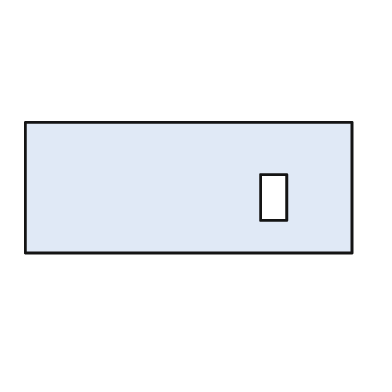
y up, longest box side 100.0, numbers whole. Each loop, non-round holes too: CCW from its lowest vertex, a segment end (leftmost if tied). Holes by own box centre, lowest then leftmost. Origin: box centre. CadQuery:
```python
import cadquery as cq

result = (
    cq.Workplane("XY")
    .moveTo(-50.0, -20.0)
    .lineTo(50.0, -20.0)
    .lineTo(50.0, 20.0)
    .lineTo(-50.0, 20.0)
    .close()
    .moveTo(22.0, -10.0)
    .lineTo(30.0, -10.0)
    .lineTo(30.0, 4.0)
    .lineTo(22.0, 4.0)
    .close()
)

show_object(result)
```